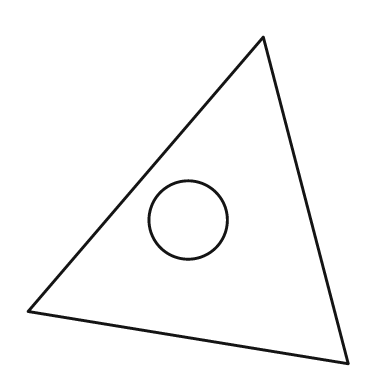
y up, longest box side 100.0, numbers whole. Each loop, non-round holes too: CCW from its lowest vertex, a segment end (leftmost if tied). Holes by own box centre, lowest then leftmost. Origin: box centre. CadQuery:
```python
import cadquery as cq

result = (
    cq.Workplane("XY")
    .moveTo(49.0, -50.0)
    .lineTo(23.0, 50.0)
    .lineTo(-49.0, -34.0)
    .close()
    .moveTo(0.0, -6.0)
    .circle(12.0)
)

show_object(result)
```